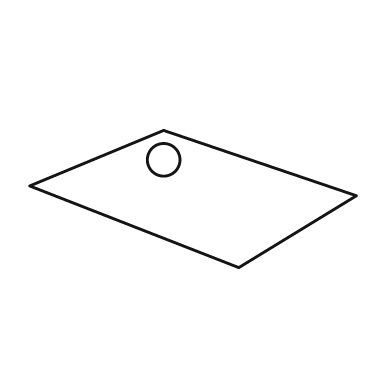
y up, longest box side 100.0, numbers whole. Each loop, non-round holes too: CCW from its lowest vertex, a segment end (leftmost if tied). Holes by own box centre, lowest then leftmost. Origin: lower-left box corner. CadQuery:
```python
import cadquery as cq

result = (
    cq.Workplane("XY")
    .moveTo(64.0, 0.0)
    .lineTo(100.0, 22.0)
    .lineTo(41.0, 42.0)
    .lineTo(0.0, 25.0)
    .close()
    .moveTo(41.0, 33.0)
    .circle(5.0)
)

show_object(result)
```